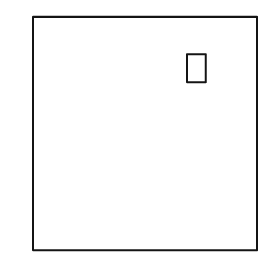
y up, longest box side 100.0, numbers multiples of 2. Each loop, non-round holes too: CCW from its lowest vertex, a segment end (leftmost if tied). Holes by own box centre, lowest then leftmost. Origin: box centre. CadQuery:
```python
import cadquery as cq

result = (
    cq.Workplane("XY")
    .moveTo(-48.0, -50.0)
    .lineTo(48.0, -50.0)
    .lineTo(48.0, 50.0)
    .lineTo(-48.0, 50.0)
    .close()
    .moveTo(18.0, 22.0)
    .lineTo(26.0, 22.0)
    .lineTo(26.0, 34.0)
    .lineTo(18.0, 34.0)
    .close()
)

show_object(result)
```